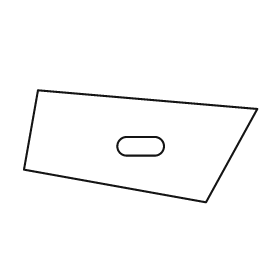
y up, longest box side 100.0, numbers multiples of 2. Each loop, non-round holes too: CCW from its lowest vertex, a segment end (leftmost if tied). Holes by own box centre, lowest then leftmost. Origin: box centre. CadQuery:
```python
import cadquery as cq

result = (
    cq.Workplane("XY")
    .moveTo(28.0, -24.0)
    .lineTo(50.0, 16.0)
    .lineTo(-44.0, 24.0)
    .lineTo(-50.0, -10.0)
    .close()
    .moveTo(-6.0, -4.0)
    .lineTo(6.0, -4.0)
    .threePointArc((10.0, 0.0), (6.0, 4.0))
    .lineTo(-6.0, 4.0)
    .threePointArc((-10.0, 0.0), (-6.0, -4.0))
    .close()
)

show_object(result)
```